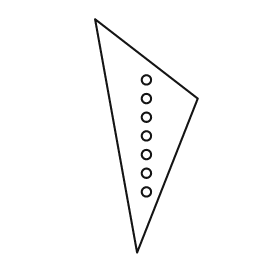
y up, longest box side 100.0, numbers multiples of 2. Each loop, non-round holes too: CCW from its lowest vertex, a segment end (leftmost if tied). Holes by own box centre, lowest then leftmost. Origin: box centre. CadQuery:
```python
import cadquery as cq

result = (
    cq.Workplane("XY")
    .moveTo(-4.0, -50.0)
    .lineTo(22.0, 16.0)
    .lineTo(-22.0, 50.0)
    .close()
    .moveTo(0.0, -24.0)
    .circle(2.0)
    .moveTo(0.0, -16.0)
    .circle(2.0)
    .moveTo(0.0, -8.0)
    .circle(2.0)
    .moveTo(0.0, 0.0)
    .circle(2.0)
    .moveTo(0.0, 8.0)
    .circle(2.0)
    .moveTo(0.0, 16.0)
    .circle(2.0)
    .moveTo(0.0, 24.0)
    .circle(2.0)
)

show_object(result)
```